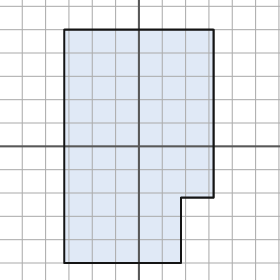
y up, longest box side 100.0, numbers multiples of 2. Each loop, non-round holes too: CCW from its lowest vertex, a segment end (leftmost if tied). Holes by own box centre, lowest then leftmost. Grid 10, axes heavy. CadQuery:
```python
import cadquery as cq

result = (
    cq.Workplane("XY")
    .moveTo(-32.0, -50.0)
    .lineTo(18.0, -50.0)
    .lineTo(18.0, -22.0)
    .lineTo(32.0, -22.0)
    .lineTo(32.0, 50.0)
    .lineTo(-32.0, 50.0)
    .close()
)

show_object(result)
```